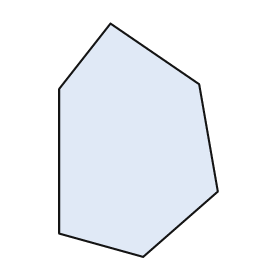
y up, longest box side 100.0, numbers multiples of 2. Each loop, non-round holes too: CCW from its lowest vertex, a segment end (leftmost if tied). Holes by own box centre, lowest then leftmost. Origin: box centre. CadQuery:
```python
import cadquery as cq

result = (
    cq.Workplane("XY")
    .moveTo(2.0, -50.0)
    .lineTo(34.0, -22.0)
    .lineTo(26.0, 24.0)
    .lineTo(-12.0, 50.0)
    .lineTo(-34.0, 22.0)
    .lineTo(-34.0, -40.0)
    .close()
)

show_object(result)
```